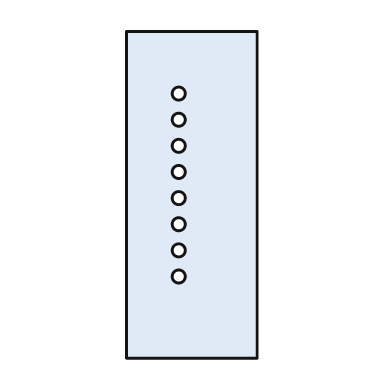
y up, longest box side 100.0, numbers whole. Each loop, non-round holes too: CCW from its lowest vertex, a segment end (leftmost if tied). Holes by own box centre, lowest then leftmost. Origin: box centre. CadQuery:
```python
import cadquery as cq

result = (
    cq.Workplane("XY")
    .moveTo(-20.0, -50.0)
    .lineTo(20.0, -50.0)
    .lineTo(20.0, 50.0)
    .lineTo(-20.0, 50.0)
    .close()
    .moveTo(-4.0, -25.0)
    .circle(2.0)
    .moveTo(-4.0, -17.0)
    .circle(2.0)
    .moveTo(-4.0, -9.0)
    .circle(2.0)
    .moveTo(-4.0, -1.0)
    .circle(2.0)
    .moveTo(-4.0, 7.0)
    .circle(2.0)
    .moveTo(-4.0, 15.0)
    .circle(2.0)
    .moveTo(-4.0, 23.0)
    .circle(2.0)
    .moveTo(-4.0, 31.0)
    .circle(2.0)
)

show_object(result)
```